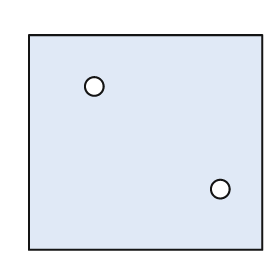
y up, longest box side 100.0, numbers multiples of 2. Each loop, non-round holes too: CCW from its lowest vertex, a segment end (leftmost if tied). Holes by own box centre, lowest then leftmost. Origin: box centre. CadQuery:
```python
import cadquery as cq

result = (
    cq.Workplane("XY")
    .moveTo(-50.0, -46.0)
    .lineTo(50.0, -46.0)
    .lineTo(50.0, 46.0)
    .lineTo(-50.0, 46.0)
    .close()
    .moveTo(32.0, -20.0)
    .circle(4.0)
    .moveTo(-22.0, 24.0)
    .circle(4.0)
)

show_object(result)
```